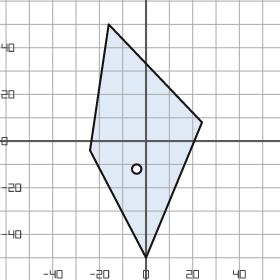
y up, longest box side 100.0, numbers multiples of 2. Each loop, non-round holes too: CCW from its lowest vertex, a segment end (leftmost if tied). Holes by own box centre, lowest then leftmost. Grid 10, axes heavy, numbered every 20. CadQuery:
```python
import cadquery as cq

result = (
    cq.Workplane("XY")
    .moveTo(0.0, -50.0)
    .lineTo(24.0, 8.0)
    .lineTo(-16.0, 50.0)
    .lineTo(-24.0, -4.0)
    .close()
    .moveTo(-4.0, -12.0)
    .circle(2.0)
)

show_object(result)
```